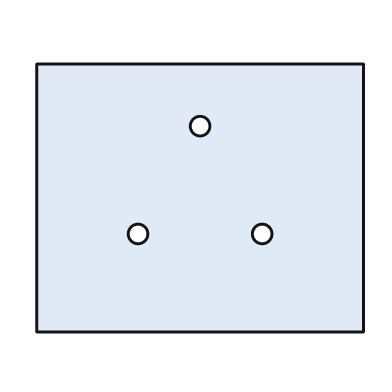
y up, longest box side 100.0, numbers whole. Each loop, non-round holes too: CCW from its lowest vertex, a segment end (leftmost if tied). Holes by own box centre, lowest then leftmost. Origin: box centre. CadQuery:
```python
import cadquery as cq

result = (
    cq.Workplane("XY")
    .moveTo(-50.0, -41.0)
    .lineTo(50.0, -41.0)
    .lineTo(50.0, 41.0)
    .lineTo(-50.0, 41.0)
    .close()
    .moveTo(-19.0, -11.0)
    .circle(3.0)
    .moveTo(19.0, -11.0)
    .circle(3.0)
    .moveTo(0.0, 22.0)
    .circle(3.0)
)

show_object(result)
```